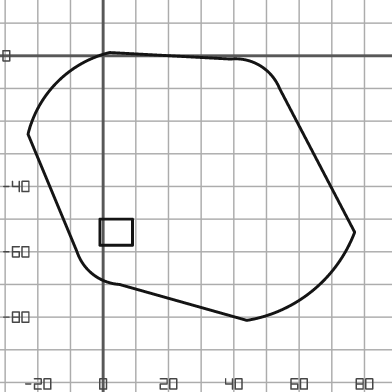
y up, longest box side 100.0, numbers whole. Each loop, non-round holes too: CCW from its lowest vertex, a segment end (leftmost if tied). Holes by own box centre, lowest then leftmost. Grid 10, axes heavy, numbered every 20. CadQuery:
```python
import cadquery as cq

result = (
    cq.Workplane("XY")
    .moveTo(44.0, -81.0)
    .threePointArc((64.0, -72.0), (77.0, -54.0))
    .lineTo(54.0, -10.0)
    .threePointArc((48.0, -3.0), (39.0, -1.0))
    .lineTo(2.0, 1.0)
    .threePointArc((-14.0, -8.0), (-23.0, -24.0))
    .lineTo(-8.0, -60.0)
    .threePointArc((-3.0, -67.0), (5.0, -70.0))
    .close()
    .moveTo(-1.0, -58.0)
    .lineTo(9.0, -58.0)
    .lineTo(9.0, -50.0)
    .lineTo(-1.0, -50.0)
    .close()
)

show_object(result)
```